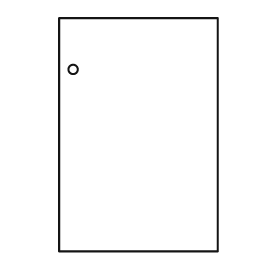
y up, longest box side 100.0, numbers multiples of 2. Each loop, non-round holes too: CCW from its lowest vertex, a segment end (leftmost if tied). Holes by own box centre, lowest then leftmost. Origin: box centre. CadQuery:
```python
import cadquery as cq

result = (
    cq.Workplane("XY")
    .moveTo(-34.0, -50.0)
    .lineTo(34.0, -50.0)
    .lineTo(34.0, 50.0)
    .lineTo(-34.0, 50.0)
    .close()
    .moveTo(-28.0, 28.0)
    .circle(2.0)
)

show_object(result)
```